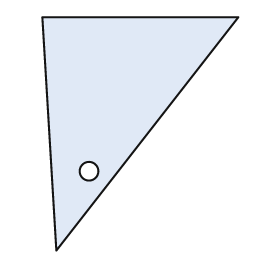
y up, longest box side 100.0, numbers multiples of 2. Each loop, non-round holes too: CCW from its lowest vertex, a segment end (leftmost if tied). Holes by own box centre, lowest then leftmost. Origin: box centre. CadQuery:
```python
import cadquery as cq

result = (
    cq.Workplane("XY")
    .moveTo(-36.0, -50.0)
    .lineTo(42.0, 50.0)
    .lineTo(-42.0, 50.0)
    .close()
    .moveTo(-22.0, -16.0)
    .circle(4.0)
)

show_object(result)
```